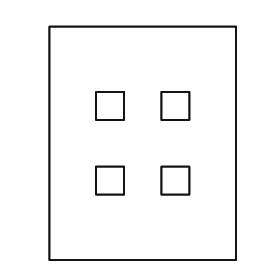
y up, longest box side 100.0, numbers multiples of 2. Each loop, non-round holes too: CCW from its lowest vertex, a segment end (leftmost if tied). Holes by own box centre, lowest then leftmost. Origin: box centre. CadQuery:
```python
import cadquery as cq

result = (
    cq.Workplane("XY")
    .moveTo(-40.0, -50.0)
    .lineTo(40.0, -50.0)
    .lineTo(40.0, 50.0)
    .lineTo(-40.0, 50.0)
    .close()
    .moveTo(-20.0, -22.0)
    .lineTo(-8.0, -22.0)
    .lineTo(-8.0, -10.0)
    .lineTo(-20.0, -10.0)
    .close()
    .moveTo(8.0, -22.0)
    .lineTo(20.0, -22.0)
    .lineTo(20.0, -10.0)
    .lineTo(8.0, -10.0)
    .close()
    .moveTo(-20.0, 10.0)
    .lineTo(-8.0, 10.0)
    .lineTo(-8.0, 22.0)
    .lineTo(-20.0, 22.0)
    .close()
    .moveTo(8.0, 10.0)
    .lineTo(20.0, 10.0)
    .lineTo(20.0, 22.0)
    .lineTo(8.0, 22.0)
    .close()
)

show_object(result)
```